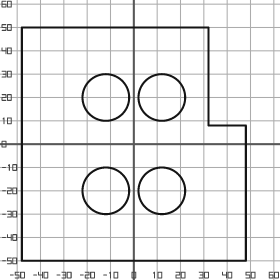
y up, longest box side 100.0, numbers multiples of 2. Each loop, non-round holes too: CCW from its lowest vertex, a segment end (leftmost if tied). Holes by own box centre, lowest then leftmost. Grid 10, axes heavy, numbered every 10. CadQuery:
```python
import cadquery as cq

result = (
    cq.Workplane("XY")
    .moveTo(-48.0, -50.0)
    .lineTo(48.0, -50.0)
    .lineTo(48.0, 8.0)
    .lineTo(32.0, 8.0)
    .lineTo(32.0, 50.0)
    .lineTo(-48.0, 50.0)
    .close()
    .moveTo(-12.0, -20.0)
    .circle(10.0)
    .moveTo(12.0, -20.0)
    .circle(10.0)
    .moveTo(-12.0, 20.0)
    .circle(10.0)
    .moveTo(12.0, 20.0)
    .circle(10.0)
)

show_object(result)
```